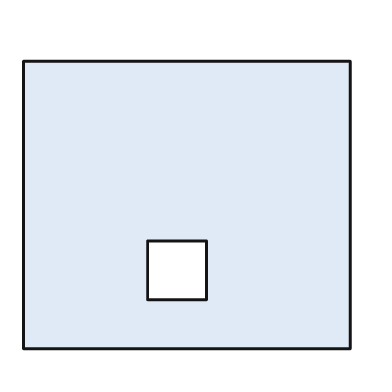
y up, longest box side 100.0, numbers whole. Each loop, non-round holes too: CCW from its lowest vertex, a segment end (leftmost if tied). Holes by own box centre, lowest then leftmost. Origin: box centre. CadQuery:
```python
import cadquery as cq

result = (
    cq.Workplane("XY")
    .moveTo(-50.0, -44.0)
    .lineTo(50.0, -44.0)
    .lineTo(50.0, 44.0)
    .lineTo(-50.0, 44.0)
    .close()
    .moveTo(-12.0, -29.0)
    .lineTo(6.0, -29.0)
    .lineTo(6.0, -11.0)
    .lineTo(-12.0, -11.0)
    .close()
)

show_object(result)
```